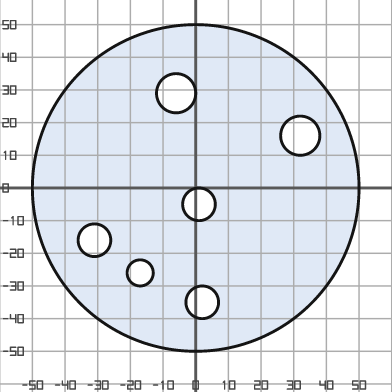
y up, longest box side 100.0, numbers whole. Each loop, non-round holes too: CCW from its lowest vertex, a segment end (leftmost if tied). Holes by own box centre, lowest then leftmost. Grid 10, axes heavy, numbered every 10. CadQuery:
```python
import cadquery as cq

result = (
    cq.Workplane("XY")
    .moveTo(0.0, 0.0)
    .circle(50.0)
    .moveTo(2.0, -35.0)
    .circle(5.0)
    .moveTo(-17.0, -26.0)
    .circle(4.0)
    .moveTo(-31.0, -16.0)
    .circle(5.0)
    .moveTo(1.0, -5.0)
    .circle(5.0)
    .moveTo(32.0, 16.0)
    .circle(6.0)
    .moveTo(-6.0, 29.0)
    .circle(6.0)
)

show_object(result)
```